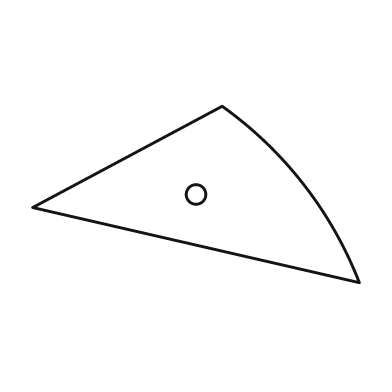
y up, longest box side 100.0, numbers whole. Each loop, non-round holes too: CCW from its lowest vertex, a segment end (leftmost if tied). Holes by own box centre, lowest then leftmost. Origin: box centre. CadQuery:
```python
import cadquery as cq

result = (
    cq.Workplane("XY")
    .moveTo(50.0, -27.0)
    .threePointArc((33.0, 3.0), (8.0, 27.0))
    .lineTo(-50.0, -4.0)
    .close()
    .moveTo(0.0, 0.0)
    .circle(3.0)
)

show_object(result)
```